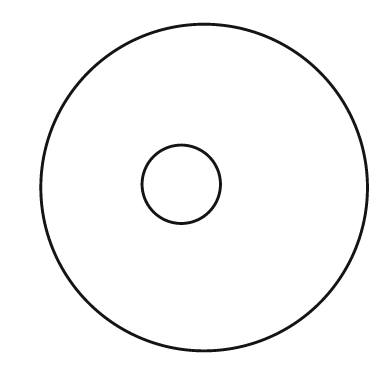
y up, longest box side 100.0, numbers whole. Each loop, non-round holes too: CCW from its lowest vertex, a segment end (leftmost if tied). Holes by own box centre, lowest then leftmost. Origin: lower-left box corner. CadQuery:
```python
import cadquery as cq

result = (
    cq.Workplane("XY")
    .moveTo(50.0, 50.0)
    .circle(50.0)
    .moveTo(43.0, 51.0)
    .circle(12.0)
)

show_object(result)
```